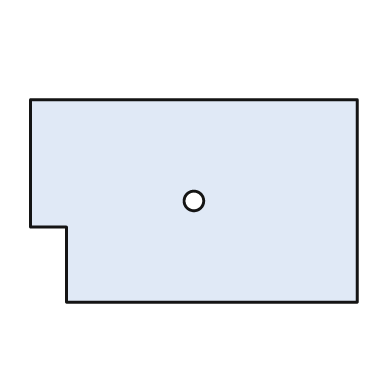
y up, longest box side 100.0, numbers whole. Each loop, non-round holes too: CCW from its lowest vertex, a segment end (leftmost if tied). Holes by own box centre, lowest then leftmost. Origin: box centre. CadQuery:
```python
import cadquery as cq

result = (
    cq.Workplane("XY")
    .moveTo(-39.0, -31.0)
    .lineTo(50.0, -31.0)
    .lineTo(50.0, 31.0)
    .lineTo(-50.0, 31.0)
    .lineTo(-50.0, -8.0)
    .lineTo(-39.0, -8.0)
    .close()
    .moveTo(0.0, 0.0)
    .circle(3.0)
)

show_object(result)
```